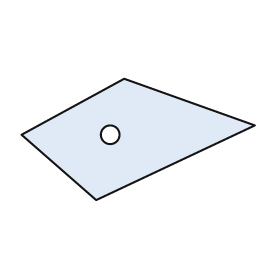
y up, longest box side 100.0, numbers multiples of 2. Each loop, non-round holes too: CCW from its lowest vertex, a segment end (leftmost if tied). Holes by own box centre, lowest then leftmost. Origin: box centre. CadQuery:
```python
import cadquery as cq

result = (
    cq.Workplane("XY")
    .moveTo(-18.0, -26.0)
    .lineTo(50.0, 6.0)
    .lineTo(-6.0, 26.0)
    .lineTo(-50.0, 2.0)
    .close()
    .moveTo(-12.0, 2.0)
    .circle(4.0)
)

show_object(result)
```